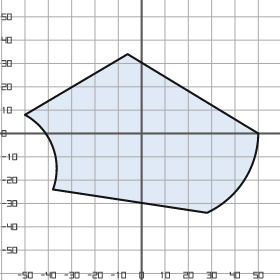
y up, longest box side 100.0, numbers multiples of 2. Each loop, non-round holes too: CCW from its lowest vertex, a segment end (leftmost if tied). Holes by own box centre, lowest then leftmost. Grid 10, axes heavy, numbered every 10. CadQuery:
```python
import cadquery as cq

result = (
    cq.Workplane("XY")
    .moveTo(28.0, -34.0)
    .threePointArc((44.0, -20.0), (50.0, 0.0))
    .lineTo(-6.0, 34.0)
    .lineTo(-50.0, 8.0)
    .threePointArc((-38.0, -6.0), (-38.0, -24.0))
    .close()
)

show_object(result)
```